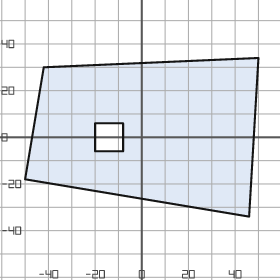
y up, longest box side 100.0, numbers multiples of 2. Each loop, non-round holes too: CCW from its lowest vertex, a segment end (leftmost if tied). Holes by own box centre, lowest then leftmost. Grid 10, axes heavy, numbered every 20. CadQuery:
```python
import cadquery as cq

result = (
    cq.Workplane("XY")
    .moveTo(46.0, -34.0)
    .lineTo(50.0, 34.0)
    .lineTo(-42.0, 30.0)
    .lineTo(-50.0, -18.0)
    .close()
    .moveTo(-20.0, -6.0)
    .lineTo(-8.0, -6.0)
    .lineTo(-8.0, 6.0)
    .lineTo(-20.0, 6.0)
    .close()
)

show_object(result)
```